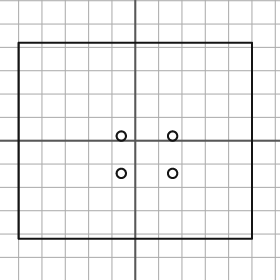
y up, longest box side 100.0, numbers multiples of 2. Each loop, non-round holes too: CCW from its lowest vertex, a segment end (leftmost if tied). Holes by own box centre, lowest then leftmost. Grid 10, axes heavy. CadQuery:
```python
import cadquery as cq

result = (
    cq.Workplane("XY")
    .moveTo(-50.0, -42.0)
    .lineTo(50.0, -42.0)
    .lineTo(50.0, 42.0)
    .lineTo(-50.0, 42.0)
    .close()
    .moveTo(-6.0, -14.0)
    .circle(2.0)
    .moveTo(16.0, -14.0)
    .circle(2.0)
    .moveTo(-6.0, 2.0)
    .circle(2.0)
    .moveTo(16.0, 2.0)
    .circle(2.0)
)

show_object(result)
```